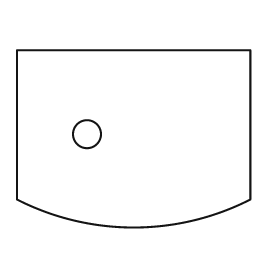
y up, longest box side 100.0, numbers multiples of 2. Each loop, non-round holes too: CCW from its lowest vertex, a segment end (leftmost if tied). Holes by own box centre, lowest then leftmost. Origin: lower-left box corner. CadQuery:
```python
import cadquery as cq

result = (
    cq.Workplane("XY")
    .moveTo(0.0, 12.0)
    .threePointArc((50.0, 0.0), (100.0, 12.0))
    .lineTo(100.0, 76.0)
    .lineTo(0.0, 76.0)
    .close()
    .moveTo(30.0, 40.0)
    .circle(6.0)
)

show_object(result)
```